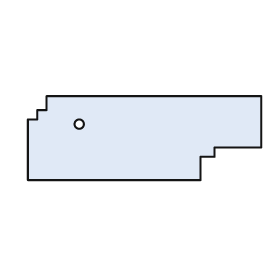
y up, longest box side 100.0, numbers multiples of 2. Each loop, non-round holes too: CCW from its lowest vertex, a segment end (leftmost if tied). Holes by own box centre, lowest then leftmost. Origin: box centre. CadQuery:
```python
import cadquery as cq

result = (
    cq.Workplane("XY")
    .moveTo(-50.0, -18.0)
    .lineTo(24.0, -18.0)
    .lineTo(24.0, -8.0)
    .lineTo(30.0, -8.0)
    .lineTo(30.0, -4.0)
    .lineTo(50.0, -4.0)
    .lineTo(50.0, 18.0)
    .lineTo(-42.0, 18.0)
    .lineTo(-42.0, 12.0)
    .lineTo(-46.0, 12.0)
    .lineTo(-46.0, 8.0)
    .lineTo(-50.0, 8.0)
    .close()
    .moveTo(-28.0, 6.0)
    .circle(2.0)
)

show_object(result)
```